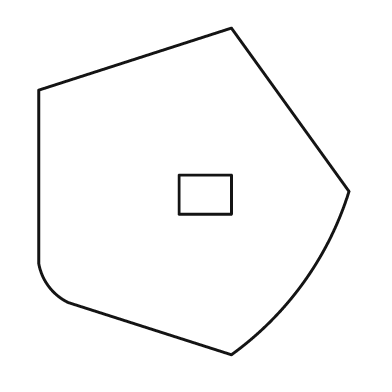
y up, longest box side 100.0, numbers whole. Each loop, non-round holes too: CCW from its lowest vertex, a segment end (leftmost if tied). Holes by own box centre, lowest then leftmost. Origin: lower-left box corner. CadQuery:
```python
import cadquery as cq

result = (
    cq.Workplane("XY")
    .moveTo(59.0, 0.0)
    .threePointArc((81.0, 22.0), (95.0, 50.0))
    .lineTo(59.0, 100.0)
    .lineTo(0.0, 81.0)
    .lineTo(0.0, 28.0)
    .threePointArc((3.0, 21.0), (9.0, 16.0))
    .close()
    .moveTo(43.0, 43.0)
    .lineTo(59.0, 43.0)
    .lineTo(59.0, 55.0)
    .lineTo(43.0, 55.0)
    .close()
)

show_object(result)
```